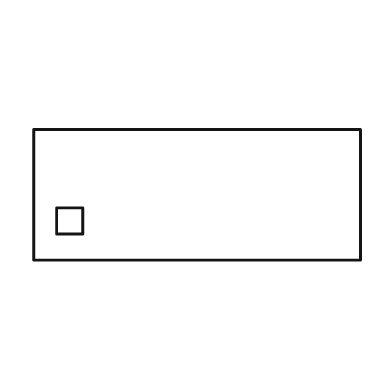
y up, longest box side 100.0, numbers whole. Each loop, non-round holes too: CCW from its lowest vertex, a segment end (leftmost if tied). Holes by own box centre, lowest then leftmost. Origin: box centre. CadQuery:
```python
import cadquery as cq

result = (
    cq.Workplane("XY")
    .moveTo(-50.0, -20.0)
    .lineTo(50.0, -20.0)
    .lineTo(50.0, 20.0)
    .lineTo(-50.0, 20.0)
    .close()
    .moveTo(-43.0, -12.0)
    .lineTo(-35.0, -12.0)
    .lineTo(-35.0, -4.0)
    .lineTo(-43.0, -4.0)
    .close()
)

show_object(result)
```